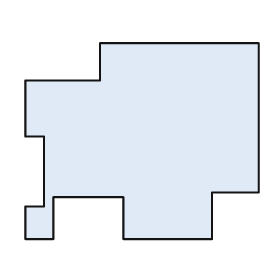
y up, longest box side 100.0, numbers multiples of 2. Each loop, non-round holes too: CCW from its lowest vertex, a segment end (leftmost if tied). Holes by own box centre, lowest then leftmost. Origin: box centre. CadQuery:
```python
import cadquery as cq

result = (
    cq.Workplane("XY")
    .moveTo(-50.0, -42.0)
    .lineTo(-38.0, -42.0)
    .lineTo(-38.0, -24.0)
    .lineTo(-8.0, -24.0)
    .lineTo(-8.0, -42.0)
    .lineTo(30.0, -42.0)
    .lineTo(30.0, -22.0)
    .lineTo(50.0, -22.0)
    .lineTo(50.0, 42.0)
    .lineTo(-18.0, 42.0)
    .lineTo(-18.0, 26.0)
    .lineTo(-50.0, 26.0)
    .lineTo(-50.0, 2.0)
    .lineTo(-42.0, 2.0)
    .lineTo(-42.0, -28.0)
    .lineTo(-50.0, -28.0)
    .close()
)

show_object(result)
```